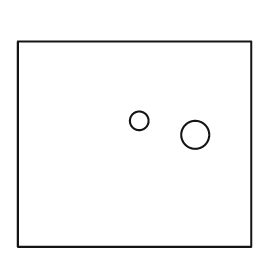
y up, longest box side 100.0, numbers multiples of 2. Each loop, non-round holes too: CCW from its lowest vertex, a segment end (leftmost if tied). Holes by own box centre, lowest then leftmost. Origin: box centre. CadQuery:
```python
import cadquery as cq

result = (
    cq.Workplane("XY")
    .moveTo(-50.0, -44.0)
    .lineTo(50.0, -44.0)
    .lineTo(50.0, 44.0)
    .lineTo(-50.0, 44.0)
    .close()
    .moveTo(26.0, 4.0)
    .circle(6.0)
    .moveTo(2.0, 10.0)
    .circle(4.0)
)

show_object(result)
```